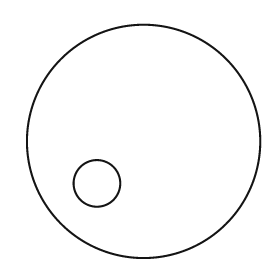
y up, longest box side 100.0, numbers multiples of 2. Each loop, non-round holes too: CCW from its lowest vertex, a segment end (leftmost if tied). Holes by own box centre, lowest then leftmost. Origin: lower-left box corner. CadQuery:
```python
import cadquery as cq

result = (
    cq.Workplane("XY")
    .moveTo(50.0, 50.0)
    .circle(50.0)
    .moveTo(30.0, 32.0)
    .circle(10.0)
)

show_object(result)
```